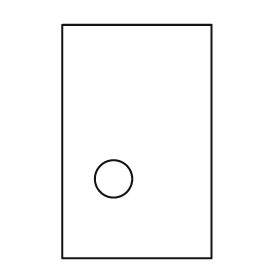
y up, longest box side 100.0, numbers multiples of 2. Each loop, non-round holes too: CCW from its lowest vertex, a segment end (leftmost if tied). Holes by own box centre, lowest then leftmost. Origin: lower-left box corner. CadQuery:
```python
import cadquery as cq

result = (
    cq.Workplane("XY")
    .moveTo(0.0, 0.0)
    .lineTo(64.0, 0.0)
    .lineTo(64.0, 100.0)
    .lineTo(0.0, 100.0)
    .close()
    .moveTo(22.0, 34.0)
    .circle(8.0)
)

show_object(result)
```